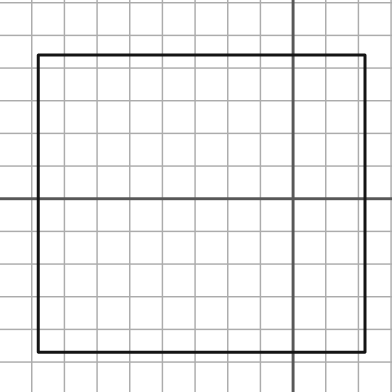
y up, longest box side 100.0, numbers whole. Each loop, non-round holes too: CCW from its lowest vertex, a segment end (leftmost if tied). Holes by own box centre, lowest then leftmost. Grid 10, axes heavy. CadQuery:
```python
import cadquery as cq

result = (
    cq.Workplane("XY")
    .moveTo(-78.0, -47.0)
    .lineTo(22.0, -47.0)
    .lineTo(22.0, 44.0)
    .lineTo(-78.0, 44.0)
    .close()
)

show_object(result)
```